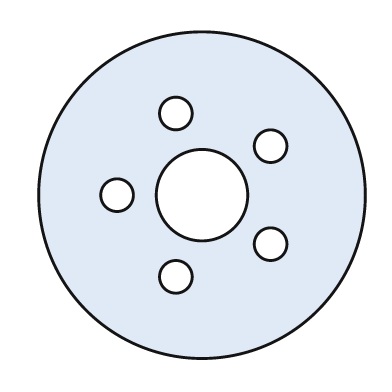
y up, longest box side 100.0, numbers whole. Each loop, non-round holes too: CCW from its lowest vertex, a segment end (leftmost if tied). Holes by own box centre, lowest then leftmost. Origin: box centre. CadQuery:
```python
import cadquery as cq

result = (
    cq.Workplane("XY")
    .moveTo(0.0, 0.0)
    .circle(50.0)
    .moveTo(-8.0, -25.0)
    .circle(5.0)
    .moveTo(21.0, -15.0)
    .circle(5.0)
    .moveTo(-26.0, 0.0)
    .circle(5.0)
    .moveTo(0.0, 0.0)
    .circle(14.0)
    .moveTo(21.0, 15.0)
    .circle(5.0)
    .moveTo(-8.0, 25.0)
    .circle(5.0)
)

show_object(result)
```